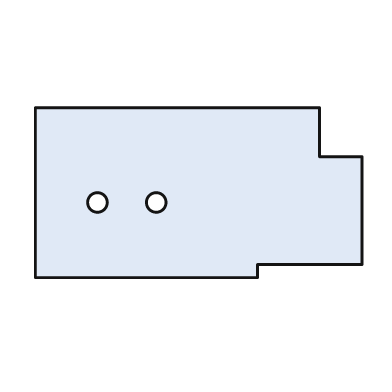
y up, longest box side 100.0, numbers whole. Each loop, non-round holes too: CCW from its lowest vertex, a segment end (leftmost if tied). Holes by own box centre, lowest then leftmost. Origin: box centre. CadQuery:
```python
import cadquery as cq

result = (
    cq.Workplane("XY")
    .moveTo(-50.0, -26.0)
    .lineTo(18.0, -26.0)
    .lineTo(18.0, -22.0)
    .lineTo(50.0, -22.0)
    .lineTo(50.0, 11.0)
    .lineTo(37.0, 11.0)
    .lineTo(37.0, 26.0)
    .lineTo(-50.0, 26.0)
    .close()
    .moveTo(-31.0, -3.0)
    .circle(3.0)
    .moveTo(-13.0, -3.0)
    .circle(3.0)
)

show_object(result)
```